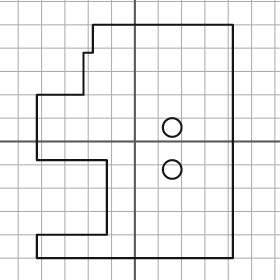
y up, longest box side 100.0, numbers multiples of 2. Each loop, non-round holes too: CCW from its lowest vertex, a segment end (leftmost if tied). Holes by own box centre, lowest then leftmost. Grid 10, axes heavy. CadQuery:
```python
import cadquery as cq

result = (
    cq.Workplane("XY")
    .moveTo(-42.0, -50.0)
    .lineTo(42.0, -50.0)
    .lineTo(42.0, 50.0)
    .lineTo(-18.0, 50.0)
    .lineTo(-18.0, 38.0)
    .lineTo(-22.0, 38.0)
    .lineTo(-22.0, 20.0)
    .lineTo(-42.0, 20.0)
    .lineTo(-42.0, -8.0)
    .lineTo(-12.0, -8.0)
    .lineTo(-12.0, -40.0)
    .lineTo(-42.0, -40.0)
    .close()
    .moveTo(16.0, -12.0)
    .circle(4.0)
    .moveTo(16.0, 6.0)
    .circle(4.0)
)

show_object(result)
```